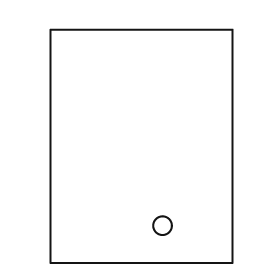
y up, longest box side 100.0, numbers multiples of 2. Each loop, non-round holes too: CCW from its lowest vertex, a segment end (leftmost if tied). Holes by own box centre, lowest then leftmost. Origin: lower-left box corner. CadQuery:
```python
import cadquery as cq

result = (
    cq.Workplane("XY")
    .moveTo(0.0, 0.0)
    .lineTo(78.0, 0.0)
    .lineTo(78.0, 100.0)
    .lineTo(0.0, 100.0)
    .close()
    .moveTo(48.0, 16.0)
    .circle(4.0)
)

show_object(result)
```